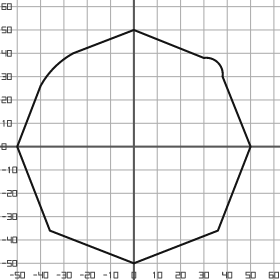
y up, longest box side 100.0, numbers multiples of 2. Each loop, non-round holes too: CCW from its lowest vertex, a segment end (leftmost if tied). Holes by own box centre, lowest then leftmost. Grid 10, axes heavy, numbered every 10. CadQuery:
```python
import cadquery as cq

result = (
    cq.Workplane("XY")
    .moveTo(0.0, -50.0)
    .lineTo(36.0, -36.0)
    .lineTo(50.0, 0.0)
    .lineTo(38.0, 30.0)
    .threePointArc((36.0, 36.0), (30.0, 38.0))
    .lineTo(0.0, 50.0)
    .lineTo(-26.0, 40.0)
    .threePointArc((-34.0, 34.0), (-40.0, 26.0))
    .lineTo(-50.0, 0.0)
    .lineTo(-36.0, -36.0)
    .close()
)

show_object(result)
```